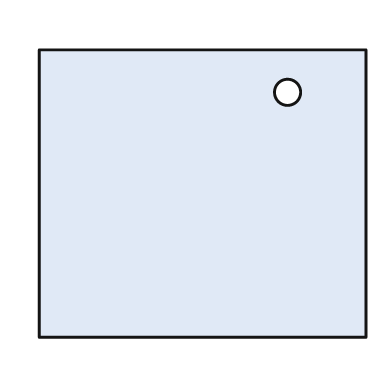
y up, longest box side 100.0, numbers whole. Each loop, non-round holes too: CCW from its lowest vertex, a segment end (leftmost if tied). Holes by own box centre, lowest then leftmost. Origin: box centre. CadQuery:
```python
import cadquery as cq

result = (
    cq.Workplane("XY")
    .moveTo(-50.0, -44.0)
    .lineTo(50.0, -44.0)
    .lineTo(50.0, 44.0)
    .lineTo(-50.0, 44.0)
    .close()
    .moveTo(26.0, 31.0)
    .circle(4.0)
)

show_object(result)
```